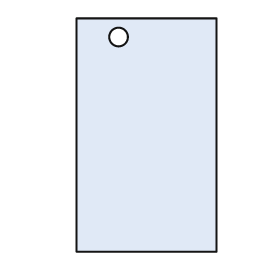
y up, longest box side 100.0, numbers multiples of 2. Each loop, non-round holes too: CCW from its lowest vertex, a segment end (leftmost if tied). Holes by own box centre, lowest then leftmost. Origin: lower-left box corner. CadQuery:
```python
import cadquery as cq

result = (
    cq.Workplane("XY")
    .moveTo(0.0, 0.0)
    .lineTo(60.0, 0.0)
    .lineTo(60.0, 100.0)
    .lineTo(0.0, 100.0)
    .close()
    .moveTo(18.0, 92.0)
    .circle(4.0)
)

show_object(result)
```